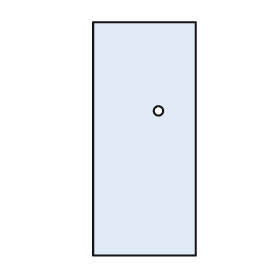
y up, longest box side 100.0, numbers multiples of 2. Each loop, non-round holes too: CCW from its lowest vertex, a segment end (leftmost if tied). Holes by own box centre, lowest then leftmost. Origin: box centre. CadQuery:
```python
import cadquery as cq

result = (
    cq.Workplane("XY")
    .moveTo(-22.0, -50.0)
    .lineTo(22.0, -50.0)
    .lineTo(22.0, 50.0)
    .lineTo(-22.0, 50.0)
    .close()
    .moveTo(6.0, 12.0)
    .circle(2.0)
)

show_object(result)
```